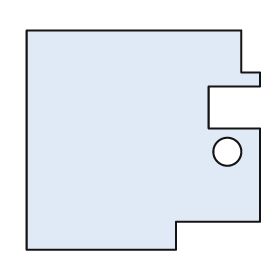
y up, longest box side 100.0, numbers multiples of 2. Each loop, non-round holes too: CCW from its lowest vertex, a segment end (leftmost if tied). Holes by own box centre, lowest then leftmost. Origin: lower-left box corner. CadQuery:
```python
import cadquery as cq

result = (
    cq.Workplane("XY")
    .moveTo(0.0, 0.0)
    .lineTo(64.0, 0.0)
    .lineTo(64.0, 12.0)
    .lineTo(100.0, 12.0)
    .lineTo(100.0, 52.0)
    .lineTo(78.0, 52.0)
    .lineTo(78.0, 70.0)
    .lineTo(100.0, 70.0)
    .lineTo(100.0, 76.0)
    .lineTo(92.0, 76.0)
    .lineTo(92.0, 94.0)
    .lineTo(0.0, 94.0)
    .close()
    .moveTo(86.0, 42.0)
    .circle(6.0)
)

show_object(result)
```